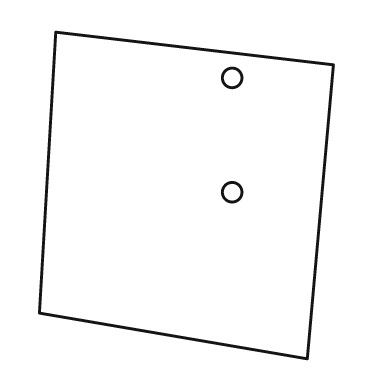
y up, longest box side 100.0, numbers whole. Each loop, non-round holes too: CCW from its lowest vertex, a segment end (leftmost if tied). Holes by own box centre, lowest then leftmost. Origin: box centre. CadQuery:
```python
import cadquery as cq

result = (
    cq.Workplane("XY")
    .moveTo(37.0, -50.0)
    .lineTo(45.0, 40.0)
    .lineTo(-40.0, 50.0)
    .lineTo(-45.0, -36.0)
    .close()
    .moveTo(14.0, 1.0)
    .circle(3.0)
    .moveTo(14.0, 36.0)
    .circle(3.0)
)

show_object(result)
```